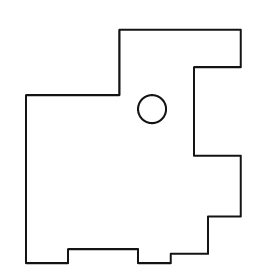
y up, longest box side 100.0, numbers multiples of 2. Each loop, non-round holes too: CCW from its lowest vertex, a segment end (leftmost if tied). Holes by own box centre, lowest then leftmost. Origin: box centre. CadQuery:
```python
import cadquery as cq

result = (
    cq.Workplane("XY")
    .moveTo(-46.0, -50.0)
    .lineTo(-28.0, -50.0)
    .lineTo(-28.0, -44.0)
    .lineTo(2.0, -44.0)
    .lineTo(2.0, -50.0)
    .lineTo(16.0, -50.0)
    .lineTo(16.0, -46.0)
    .lineTo(32.0, -46.0)
    .lineTo(32.0, -30.0)
    .lineTo(46.0, -30.0)
    .lineTo(46.0, -4.0)
    .lineTo(26.0, -4.0)
    .lineTo(26.0, 34.0)
    .lineTo(46.0, 34.0)
    .lineTo(46.0, 50.0)
    .lineTo(-6.0, 50.0)
    .lineTo(-6.0, 22.0)
    .lineTo(-46.0, 22.0)
    .close()
    .moveTo(8.0, 16.0)
    .circle(6.0)
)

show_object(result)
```